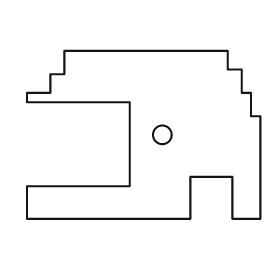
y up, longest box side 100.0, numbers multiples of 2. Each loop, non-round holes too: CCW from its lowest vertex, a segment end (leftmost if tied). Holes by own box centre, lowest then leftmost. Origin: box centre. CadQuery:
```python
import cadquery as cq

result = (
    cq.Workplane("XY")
    .moveTo(-50.0, -36.0)
    .lineTo(20.0, -36.0)
    .lineTo(20.0, -18.0)
    .lineTo(38.0, -18.0)
    .lineTo(38.0, -36.0)
    .lineTo(50.0, -36.0)
    .lineTo(50.0, 8.0)
    .lineTo(46.0, 8.0)
    .lineTo(46.0, 18.0)
    .lineTo(42.0, 18.0)
    .lineTo(42.0, 28.0)
    .lineTo(36.0, 28.0)
    .lineTo(36.0, 36.0)
    .lineTo(-34.0, 36.0)
    .lineTo(-34.0, 26.0)
    .lineTo(-40.0, 26.0)
    .lineTo(-40.0, 18.0)
    .lineTo(-50.0, 18.0)
    .lineTo(-50.0, 14.0)
    .lineTo(-6.0, 14.0)
    .lineTo(-6.0, -22.0)
    .lineTo(-50.0, -22.0)
    .close()
    .moveTo(8.0, 0.0)
    .circle(4.0)
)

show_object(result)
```